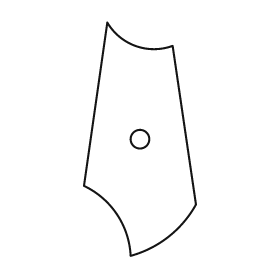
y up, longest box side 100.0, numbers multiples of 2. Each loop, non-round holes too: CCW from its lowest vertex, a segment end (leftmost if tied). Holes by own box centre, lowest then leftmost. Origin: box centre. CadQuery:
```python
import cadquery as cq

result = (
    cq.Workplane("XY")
    .moveTo(-4.0, -50.0)
    .threePointArc((12.0, -42.0), (24.0, -28.0))
    .lineTo(14.0, 40.0)
    .threePointArc((-2.0, 40.0), (-14.0, 50.0))
    .lineTo(-24.0, -20.0)
    .threePointArc((-10.0, -32.0), (-4.0, -50.0))
    .close()
    .moveTo(0.0, 0.0)
    .circle(4.0)
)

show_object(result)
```